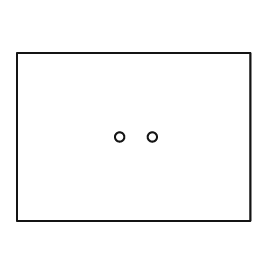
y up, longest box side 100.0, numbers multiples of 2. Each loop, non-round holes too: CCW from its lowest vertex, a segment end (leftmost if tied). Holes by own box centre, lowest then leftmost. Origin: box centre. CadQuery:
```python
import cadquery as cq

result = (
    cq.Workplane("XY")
    .moveTo(-50.0, -36.0)
    .lineTo(50.0, -36.0)
    .lineTo(50.0, 36.0)
    .lineTo(-50.0, 36.0)
    .close()
    .moveTo(-6.0, 0.0)
    .circle(2.0)
    .moveTo(8.0, 0.0)
    .circle(2.0)
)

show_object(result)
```